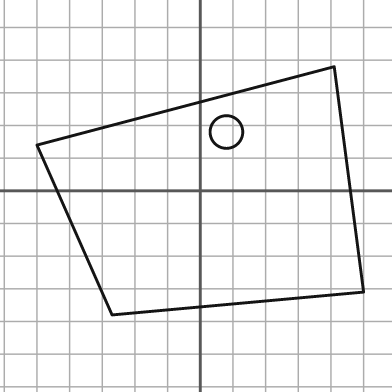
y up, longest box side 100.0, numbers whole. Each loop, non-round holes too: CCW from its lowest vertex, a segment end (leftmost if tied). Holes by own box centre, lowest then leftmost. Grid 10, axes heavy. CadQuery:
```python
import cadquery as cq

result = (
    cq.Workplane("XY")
    .moveTo(-27.0, -38.0)
    .lineTo(50.0, -31.0)
    .lineTo(41.0, 38.0)
    .lineTo(-50.0, 14.0)
    .close()
    .moveTo(8.0, 18.0)
    .circle(5.0)
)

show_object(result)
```